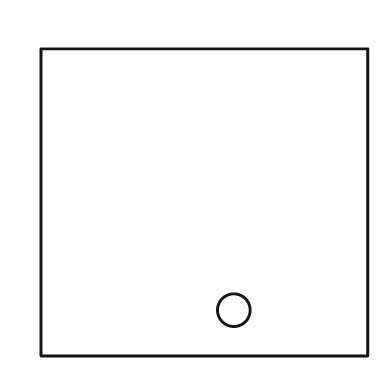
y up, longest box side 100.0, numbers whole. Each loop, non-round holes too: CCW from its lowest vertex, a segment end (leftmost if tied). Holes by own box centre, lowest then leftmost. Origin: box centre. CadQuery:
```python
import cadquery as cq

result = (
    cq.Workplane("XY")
    .moveTo(-50.0, -47.0)
    .lineTo(50.0, -47.0)
    .lineTo(50.0, 47.0)
    .lineTo(-50.0, 47.0)
    .close()
    .moveTo(9.0, -33.0)
    .circle(5.0)
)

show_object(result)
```